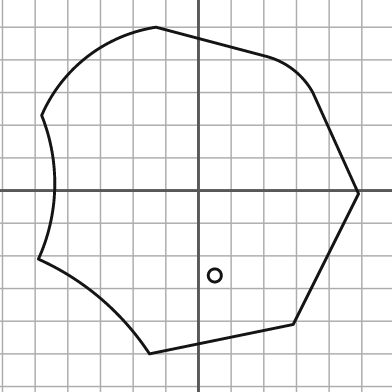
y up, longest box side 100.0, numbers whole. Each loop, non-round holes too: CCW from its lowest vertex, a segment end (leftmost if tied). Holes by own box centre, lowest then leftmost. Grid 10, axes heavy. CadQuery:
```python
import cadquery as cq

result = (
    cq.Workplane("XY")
    .moveTo(-15.0, -50.0)
    .lineTo(29.0, -41.0)
    .lineTo(49.0, -1.0)
    .lineTo(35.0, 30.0)
    .threePointArc((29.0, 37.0), (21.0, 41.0))
    .lineTo(-13.0, 50.0)
    .threePointArc((-34.0, 41.0), (-48.0, 23.0))
    .threePointArc((-44.0, 1.0), (-49.0, -21.0))
    .threePointArc((-30.0, -33.0), (-15.0, -50.0))
    .close()
    .moveTo(5.0, -26.0)
    .circle(2.0)
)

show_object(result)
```